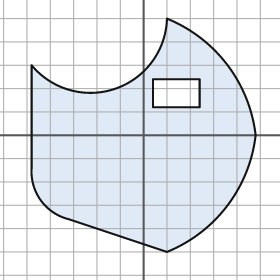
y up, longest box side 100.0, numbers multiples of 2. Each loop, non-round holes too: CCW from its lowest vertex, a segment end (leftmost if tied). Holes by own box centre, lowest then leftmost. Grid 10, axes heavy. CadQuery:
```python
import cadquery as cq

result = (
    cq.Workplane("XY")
    .moveTo(10.0, -50.0)
    .threePointArc((36.0, -30.0), (48.0, 0.0))
    .threePointArc((36.0, 30.0), (10.0, 50.0))
    .threePointArc((-12.0, 20.0), (-48.0, 30.0))
    .lineTo(-48.0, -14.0)
    .threePointArc((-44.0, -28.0), (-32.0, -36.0))
    .close()
    .moveTo(4.0, 12.0)
    .lineTo(24.0, 12.0)
    .lineTo(24.0, 24.0)
    .lineTo(4.0, 24.0)
    .close()
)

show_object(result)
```